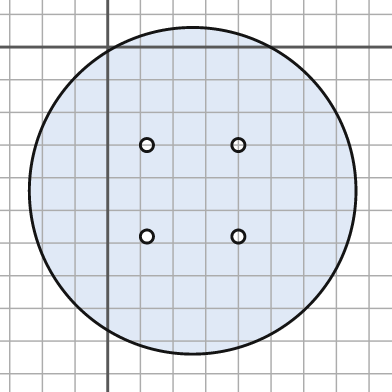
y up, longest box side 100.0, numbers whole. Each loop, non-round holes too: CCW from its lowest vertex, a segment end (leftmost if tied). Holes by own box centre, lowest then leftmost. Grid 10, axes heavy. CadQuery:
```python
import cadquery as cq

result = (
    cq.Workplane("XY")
    .moveTo(26.0, -44.0)
    .circle(50.0)
    .moveTo(12.0, -58.0)
    .circle(2.0)
    .moveTo(40.0, -58.0)
    .circle(2.0)
    .moveTo(12.0, -30.0)
    .circle(2.0)
    .moveTo(40.0, -30.0)
    .circle(2.0)
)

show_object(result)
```